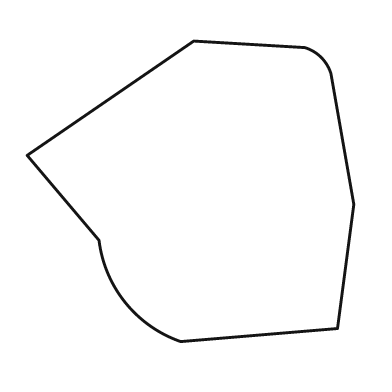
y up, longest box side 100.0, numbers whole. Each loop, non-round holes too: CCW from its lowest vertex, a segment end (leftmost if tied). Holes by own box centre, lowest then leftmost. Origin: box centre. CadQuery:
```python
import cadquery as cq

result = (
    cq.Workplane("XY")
    .moveTo(-3.0, -46.0)
    .lineTo(45.0, -42.0)
    .lineTo(50.0, -4.0)
    .lineTo(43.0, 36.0)
    .threePointArc((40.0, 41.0), (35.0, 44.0))
    .lineTo(1.0, 46.0)
    .lineTo(-50.0, 11.0)
    .lineTo(-28.0, -15.0)
    .threePointArc((-20.0, -34.0), (-3.0, -46.0))
    .close()
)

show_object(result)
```